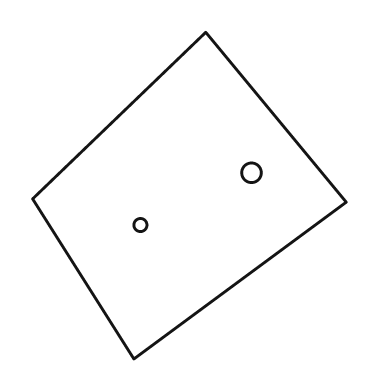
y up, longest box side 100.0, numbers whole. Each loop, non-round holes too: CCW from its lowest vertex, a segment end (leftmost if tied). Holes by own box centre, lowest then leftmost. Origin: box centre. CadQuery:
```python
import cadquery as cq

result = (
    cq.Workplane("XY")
    .moveTo(-17.0, -50.0)
    .lineTo(48.0, -2.0)
    .lineTo(5.0, 50.0)
    .lineTo(-48.0, -1.0)
    .close()
    .moveTo(-15.0, -9.0)
    .circle(2.0)
    .moveTo(19.0, 7.0)
    .circle(3.0)
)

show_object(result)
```